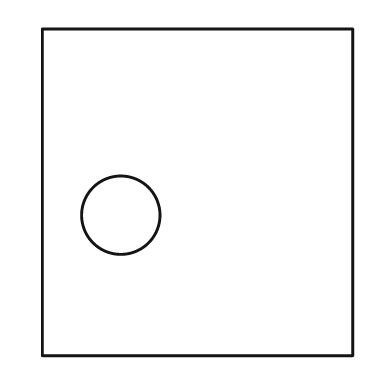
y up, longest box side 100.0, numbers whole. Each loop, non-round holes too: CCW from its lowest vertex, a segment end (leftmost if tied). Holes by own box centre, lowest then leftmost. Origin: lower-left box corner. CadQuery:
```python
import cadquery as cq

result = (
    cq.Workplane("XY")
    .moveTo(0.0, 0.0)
    .lineTo(95.0, 0.0)
    .lineTo(95.0, 100.0)
    .lineTo(0.0, 100.0)
    .close()
    .moveTo(24.0, 43.0)
    .circle(12.0)
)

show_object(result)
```